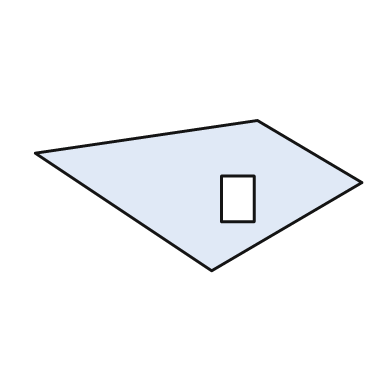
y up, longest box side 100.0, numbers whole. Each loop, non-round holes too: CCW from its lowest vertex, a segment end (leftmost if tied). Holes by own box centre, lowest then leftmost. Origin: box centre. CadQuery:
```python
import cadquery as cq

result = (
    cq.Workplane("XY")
    .moveTo(4.0, -23.0)
    .lineTo(50.0, 4.0)
    .lineTo(18.0, 23.0)
    .lineTo(-50.0, 13.0)
    .close()
    .moveTo(7.0, -8.0)
    .lineTo(17.0, -8.0)
    .lineTo(17.0, 6.0)
    .lineTo(7.0, 6.0)
    .close()
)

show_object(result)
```